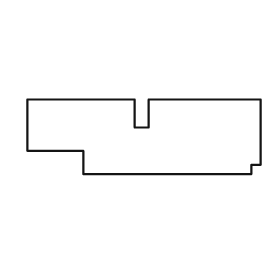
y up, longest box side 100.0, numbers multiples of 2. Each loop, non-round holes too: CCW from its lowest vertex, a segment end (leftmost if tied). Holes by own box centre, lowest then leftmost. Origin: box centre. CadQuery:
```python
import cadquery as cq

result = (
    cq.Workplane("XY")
    .moveTo(-26.0, -16.0)
    .lineTo(46.0, -16.0)
    .lineTo(46.0, -12.0)
    .lineTo(50.0, -12.0)
    .lineTo(50.0, 16.0)
    .lineTo(2.0, 16.0)
    .lineTo(2.0, 4.0)
    .lineTo(-4.0, 4.0)
    .lineTo(-4.0, 16.0)
    .lineTo(-50.0, 16.0)
    .lineTo(-50.0, -6.0)
    .lineTo(-26.0, -6.0)
    .close()
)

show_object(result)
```